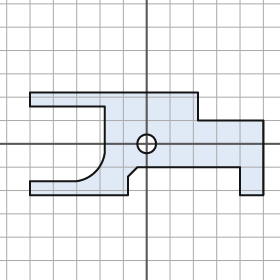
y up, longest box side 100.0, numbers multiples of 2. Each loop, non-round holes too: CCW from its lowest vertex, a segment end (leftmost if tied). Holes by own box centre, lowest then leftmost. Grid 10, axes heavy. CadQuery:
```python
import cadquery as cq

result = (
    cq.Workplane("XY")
    .moveTo(-50.0, -22.0)
    .lineTo(-8.0, -22.0)
    .lineTo(-8.0, -14.0)
    .lineTo(-4.0, -10.0)
    .lineTo(40.0, -10.0)
    .lineTo(40.0, -22.0)
    .lineTo(50.0, -22.0)
    .lineTo(50.0, 10.0)
    .lineTo(22.0, 10.0)
    .lineTo(22.0, 22.0)
    .lineTo(-50.0, 22.0)
    .lineTo(-50.0, 16.0)
    .lineTo(-18.0, 16.0)
    .lineTo(-18.0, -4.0)
    .threePointArc((-22.0, -12.0), (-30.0, -16.0))
    .lineTo(-50.0, -16.0)
    .close()
    .moveTo(0.0, 0.0)
    .circle(4.0)
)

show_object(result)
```